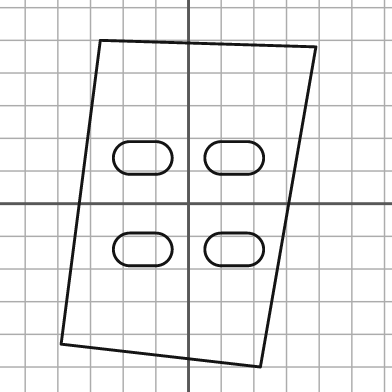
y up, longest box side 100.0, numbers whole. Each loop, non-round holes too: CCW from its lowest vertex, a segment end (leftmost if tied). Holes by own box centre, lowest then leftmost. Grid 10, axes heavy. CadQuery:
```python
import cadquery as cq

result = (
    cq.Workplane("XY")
    .moveTo(22.0, -50.0)
    .lineTo(39.0, 48.0)
    .lineTo(-27.0, 50.0)
    .lineTo(-39.0, -43.0)
    .close()
    .moveTo(-18.0, -19.0)
    .lineTo(-10.0, -19.0)
    .threePointArc((-5.0, -14.0), (-10.0, -9.0))
    .lineTo(-18.0, -9.0)
    .threePointArc((-23.0, -14.0), (-18.0, -19.0))
    .close()
    .moveTo(10.0, -19.0)
    .lineTo(18.0, -19.0)
    .threePointArc((23.0, -14.0), (18.0, -9.0))
    .lineTo(10.0, -9.0)
    .threePointArc((5.0, -14.0), (10.0, -19.0))
    .close()
    .moveTo(-18.0, 9.0)
    .lineTo(-10.0, 9.0)
    .threePointArc((-5.0, 14.0), (-10.0, 19.0))
    .lineTo(-18.0, 19.0)
    .threePointArc((-23.0, 14.0), (-18.0, 9.0))
    .close()
    .moveTo(10.0, 9.0)
    .lineTo(18.0, 9.0)
    .threePointArc((23.0, 14.0), (18.0, 19.0))
    .lineTo(10.0, 19.0)
    .threePointArc((5.0, 14.0), (10.0, 9.0))
    .close()
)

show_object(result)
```